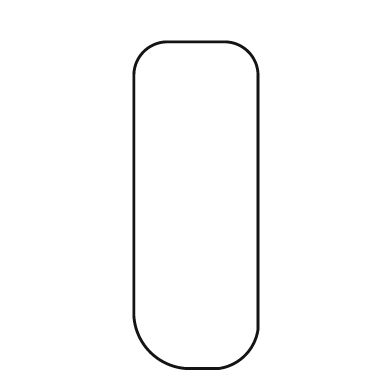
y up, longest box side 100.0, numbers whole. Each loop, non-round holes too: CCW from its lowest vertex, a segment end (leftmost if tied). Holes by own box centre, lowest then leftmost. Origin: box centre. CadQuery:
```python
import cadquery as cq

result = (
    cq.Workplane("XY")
    .moveTo(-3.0, -50.0)
    .lineTo(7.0, -50.0)
    .threePointArc((15.0, -46.0), (19.0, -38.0))
    .lineTo(19.0, 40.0)
    .threePointArc((16.0, 47.0), (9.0, 50.0))
    .lineTo(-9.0, 50.0)
    .threePointArc((-16.0, 47.0), (-19.0, 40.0))
    .lineTo(-19.0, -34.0)
    .threePointArc((-14.0, -45.0), (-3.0, -50.0))
    .close()
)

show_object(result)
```